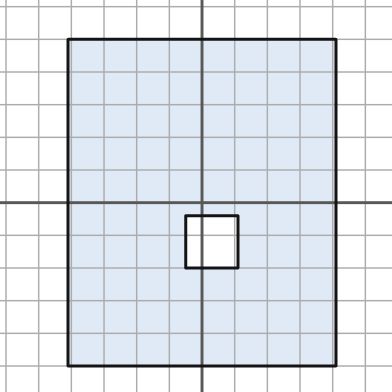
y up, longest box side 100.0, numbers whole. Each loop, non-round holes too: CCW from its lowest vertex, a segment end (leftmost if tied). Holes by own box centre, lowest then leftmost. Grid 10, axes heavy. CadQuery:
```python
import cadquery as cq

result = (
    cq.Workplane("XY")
    .moveTo(-41.0, -50.0)
    .lineTo(41.0, -50.0)
    .lineTo(41.0, 50.0)
    .lineTo(-41.0, 50.0)
    .close()
    .moveTo(-5.0, -20.0)
    .lineTo(11.0, -20.0)
    .lineTo(11.0, -4.0)
    .lineTo(-5.0, -4.0)
    .close()
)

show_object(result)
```